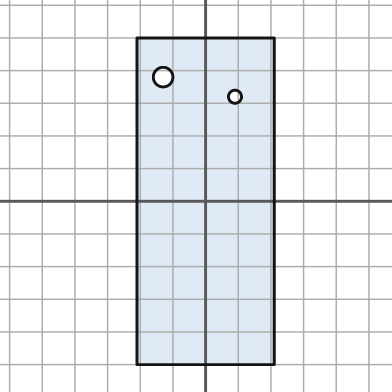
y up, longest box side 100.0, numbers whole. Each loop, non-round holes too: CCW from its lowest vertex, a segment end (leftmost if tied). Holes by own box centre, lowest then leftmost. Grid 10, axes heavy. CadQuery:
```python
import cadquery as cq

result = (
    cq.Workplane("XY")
    .moveTo(-21.0, -50.0)
    .lineTo(21.0, -50.0)
    .lineTo(21.0, 50.0)
    .lineTo(-21.0, 50.0)
    .close()
    .moveTo(9.0, 32.0)
    .circle(2.0)
    .moveTo(-13.0, 38.0)
    .circle(3.0)
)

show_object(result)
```